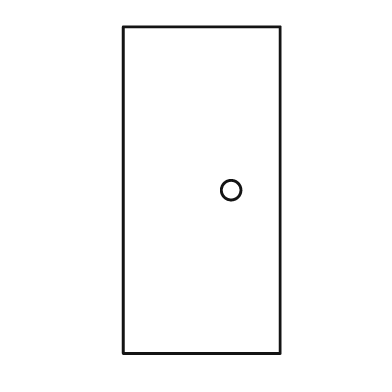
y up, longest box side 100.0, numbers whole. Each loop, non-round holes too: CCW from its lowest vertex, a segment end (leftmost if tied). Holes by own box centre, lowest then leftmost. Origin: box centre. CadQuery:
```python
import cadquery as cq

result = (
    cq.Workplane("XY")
    .moveTo(-24.0, -50.0)
    .lineTo(24.0, -50.0)
    .lineTo(24.0, 50.0)
    .lineTo(-24.0, 50.0)
    .close()
    .moveTo(9.0, 0.0)
    .circle(3.0)
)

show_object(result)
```